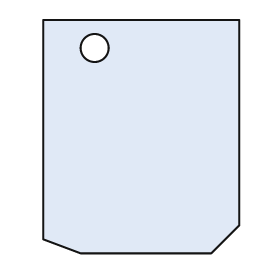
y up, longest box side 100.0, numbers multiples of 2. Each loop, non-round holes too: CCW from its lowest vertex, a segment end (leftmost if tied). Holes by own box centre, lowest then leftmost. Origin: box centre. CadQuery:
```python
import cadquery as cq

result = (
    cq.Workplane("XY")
    .moveTo(-26.0, -50.0)
    .lineTo(30.0, -50.0)
    .lineTo(42.0, -38.0)
    .lineTo(42.0, 50.0)
    .lineTo(-42.0, 50.0)
    .lineTo(-42.0, -44.0)
    .close()
    .moveTo(-20.0, 38.0)
    .circle(6.0)
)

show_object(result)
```